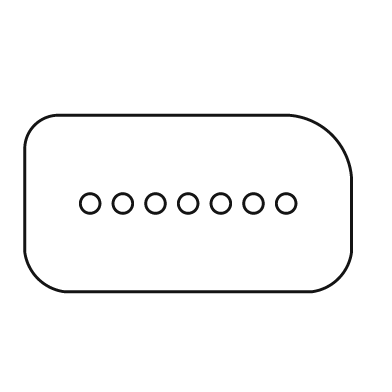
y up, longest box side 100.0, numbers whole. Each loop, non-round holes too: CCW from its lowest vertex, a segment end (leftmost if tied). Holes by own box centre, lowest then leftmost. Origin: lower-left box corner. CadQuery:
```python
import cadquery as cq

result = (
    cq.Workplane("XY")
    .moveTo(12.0, 0.0)
    .lineTo(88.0, 0.0)
    .threePointArc((96.0, 4.0), (100.0, 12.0))
    .lineTo(100.0, 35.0)
    .threePointArc((94.0, 48.0), (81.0, 54.0))
    .lineTo(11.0, 54.0)
    .threePointArc((3.0, 51.0), (0.0, 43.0))
    .lineTo(0.0, 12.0)
    .threePointArc((4.0, 4.0), (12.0, 0.0))
    .close()
    .moveTo(20.0, 27.0)
    .circle(3.0)
    .moveTo(30.0, 27.0)
    .circle(3.0)
    .moveTo(40.0, 27.0)
    .circle(3.0)
    .moveTo(50.0, 27.0)
    .circle(3.0)
    .moveTo(60.0, 27.0)
    .circle(3.0)
    .moveTo(70.0, 27.0)
    .circle(3.0)
    .moveTo(80.0, 27.0)
    .circle(3.0)
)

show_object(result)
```